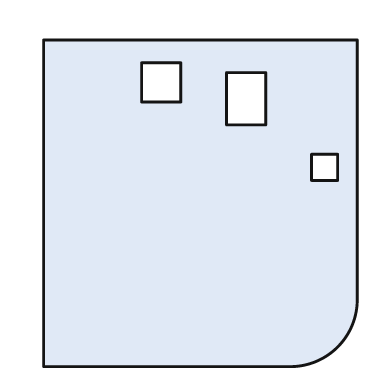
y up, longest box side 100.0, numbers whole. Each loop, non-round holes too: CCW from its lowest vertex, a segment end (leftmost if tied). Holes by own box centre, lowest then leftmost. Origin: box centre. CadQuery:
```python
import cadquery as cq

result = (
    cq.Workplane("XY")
    .moveTo(-48.0, -50.0)
    .lineTo(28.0, -50.0)
    .threePointArc((42.0, -44.0), (48.0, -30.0))
    .lineTo(48.0, 50.0)
    .lineTo(-48.0, 50.0)
    .close()
    .moveTo(34.0, 7.0)
    .lineTo(42.0, 7.0)
    .lineTo(42.0, 15.0)
    .lineTo(34.0, 15.0)
    .close()
    .moveTo(8.0, 24.0)
    .lineTo(20.0, 24.0)
    .lineTo(20.0, 40.0)
    .lineTo(8.0, 40.0)
    .close()
    .moveTo(-18.0, 31.0)
    .lineTo(-6.0, 31.0)
    .lineTo(-6.0, 43.0)
    .lineTo(-18.0, 43.0)
    .close()
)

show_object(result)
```